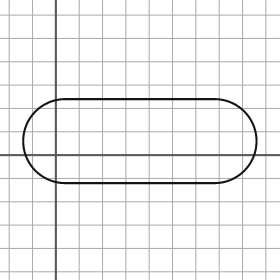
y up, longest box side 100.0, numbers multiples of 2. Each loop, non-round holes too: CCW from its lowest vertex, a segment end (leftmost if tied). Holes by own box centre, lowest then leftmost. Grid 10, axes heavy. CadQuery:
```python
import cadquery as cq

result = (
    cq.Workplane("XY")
    .moveTo(4.0, -12.0)
    .lineTo(68.0, -12.0)
    .threePointArc((86.0, 6.0), (68.0, 24.0))
    .lineTo(4.0, 24.0)
    .threePointArc((-14.0, 6.0), (4.0, -12.0))
    .close()
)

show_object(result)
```